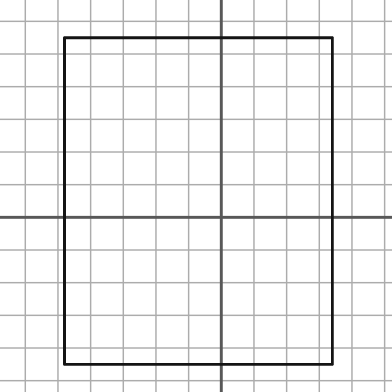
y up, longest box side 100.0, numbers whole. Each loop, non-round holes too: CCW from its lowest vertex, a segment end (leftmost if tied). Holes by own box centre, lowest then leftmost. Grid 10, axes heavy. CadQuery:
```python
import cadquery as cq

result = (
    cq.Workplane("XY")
    .moveTo(-48.0, -45.0)
    .lineTo(34.0, -45.0)
    .lineTo(34.0, 55.0)
    .lineTo(-48.0, 55.0)
    .close()
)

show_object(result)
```